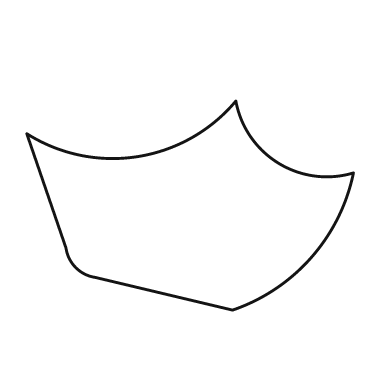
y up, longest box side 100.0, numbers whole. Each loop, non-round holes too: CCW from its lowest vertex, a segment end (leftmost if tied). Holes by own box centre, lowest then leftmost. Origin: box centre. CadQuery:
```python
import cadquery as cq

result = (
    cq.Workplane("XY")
    .moveTo(13.0, -32.0)
    .threePointArc((37.0, -16.0), (50.0, 10.0))
    .threePointArc((27.0, 13.0), (14.0, 32.0))
    .threePointArc((-16.0, 15.0), (-50.0, 22.0))
    .lineTo(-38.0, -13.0)
    .threePointArc((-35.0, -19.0), (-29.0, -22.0))
    .close()
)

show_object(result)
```